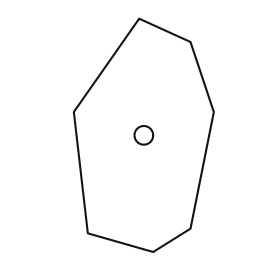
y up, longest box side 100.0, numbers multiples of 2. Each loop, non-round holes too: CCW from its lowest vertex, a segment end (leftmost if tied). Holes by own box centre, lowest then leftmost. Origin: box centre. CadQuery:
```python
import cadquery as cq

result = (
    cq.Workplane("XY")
    .moveTo(4.0, -50.0)
    .lineTo(20.0, -40.0)
    .lineTo(30.0, 10.0)
    .lineTo(20.0, 40.0)
    .lineTo(-2.0, 50.0)
    .lineTo(-30.0, 10.0)
    .lineTo(-24.0, -42.0)
    .close()
    .moveTo(0.0, 0.0)
    .circle(4.0)
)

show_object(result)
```